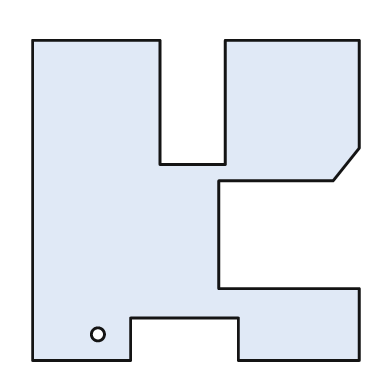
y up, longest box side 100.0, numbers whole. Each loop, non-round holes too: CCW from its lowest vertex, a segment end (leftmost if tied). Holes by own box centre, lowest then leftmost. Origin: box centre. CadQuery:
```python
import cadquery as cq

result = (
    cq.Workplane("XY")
    .moveTo(-50.0, -49.0)
    .lineTo(-20.0, -49.0)
    .lineTo(-20.0, -36.0)
    .lineTo(13.0, -36.0)
    .lineTo(13.0, -49.0)
    .lineTo(50.0, -49.0)
    .lineTo(50.0, -27.0)
    .lineTo(7.0, -27.0)
    .lineTo(7.0, 6.0)
    .lineTo(42.0, 6.0)
    .lineTo(50.0, 16.0)
    .lineTo(50.0, 49.0)
    .lineTo(9.0, 49.0)
    .lineTo(9.0, 11.0)
    .lineTo(-11.0, 11.0)
    .lineTo(-11.0, 49.0)
    .lineTo(-50.0, 49.0)
    .close()
    .moveTo(-30.0, -41.0)
    .circle(2.0)
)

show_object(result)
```